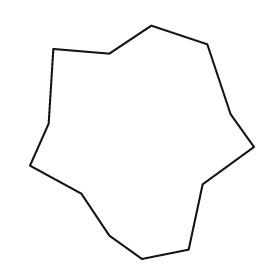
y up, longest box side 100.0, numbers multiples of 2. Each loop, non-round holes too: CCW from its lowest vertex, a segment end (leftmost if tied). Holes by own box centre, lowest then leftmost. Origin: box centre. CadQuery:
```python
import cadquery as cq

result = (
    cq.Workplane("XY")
    .moveTo(0.0, -50.0)
    .lineTo(20.0, -46.0)
    .lineTo(26.0, -18.0)
    .lineTo(48.0, -2.0)
    .lineTo(38.0, 12.0)
    .lineTo(28.0, 42.0)
    .lineTo(4.0, 50.0)
    .lineTo(-14.0, 38.0)
    .lineTo(-38.0, 40.0)
    .lineTo(-40.0, 8.0)
    .lineTo(-48.0, -10.0)
    .lineTo(-26.0, -22.0)
    .lineTo(-14.0, -40.0)
    .close()
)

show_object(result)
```